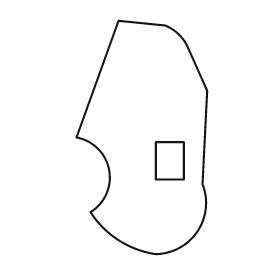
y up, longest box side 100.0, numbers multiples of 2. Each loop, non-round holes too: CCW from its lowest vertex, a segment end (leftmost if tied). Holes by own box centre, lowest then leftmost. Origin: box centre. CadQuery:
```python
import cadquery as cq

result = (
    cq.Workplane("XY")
    .moveTo(6.0, -50.0)
    .threePointArc((24.0, -40.0), (26.0, -20.0))
    .lineTo(28.0, 20.0)
    .lineTo(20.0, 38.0)
    .threePointArc((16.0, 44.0), (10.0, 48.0))
    .lineTo(-10.0, 50.0)
    .lineTo(-28.0, 0.0)
    .threePointArc((-14.0, -14.0), (-22.0, -32.0))
    .threePointArc((-10.0, -44.0), (6.0, -50.0))
    .close()
    .moveTo(6.0, -18.0)
    .lineTo(18.0, -18.0)
    .lineTo(18.0, -2.0)
    .lineTo(6.0, -2.0)
    .close()
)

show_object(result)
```